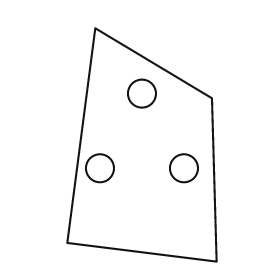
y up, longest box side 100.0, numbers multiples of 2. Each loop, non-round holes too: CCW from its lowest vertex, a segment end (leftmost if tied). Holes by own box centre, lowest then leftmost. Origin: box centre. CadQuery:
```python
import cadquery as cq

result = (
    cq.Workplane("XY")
    .moveTo(32.0, -50.0)
    .lineTo(30.0, 20.0)
    .lineTo(-20.0, 50.0)
    .lineTo(-32.0, -42.0)
    .close()
    .moveTo(-18.0, -10.0)
    .circle(6.0)
    .moveTo(18.0, -10.0)
    .circle(6.0)
    .moveTo(0.0, 22.0)
    .circle(6.0)
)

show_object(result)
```